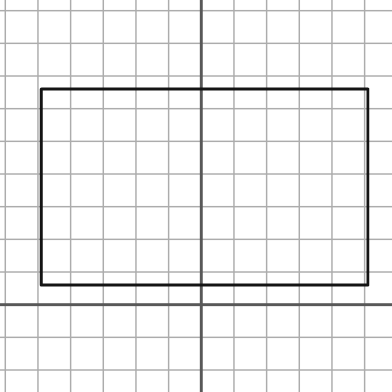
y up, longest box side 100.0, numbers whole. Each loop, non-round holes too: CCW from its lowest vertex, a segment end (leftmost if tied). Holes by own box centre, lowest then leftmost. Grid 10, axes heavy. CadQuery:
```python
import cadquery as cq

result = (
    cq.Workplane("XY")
    .moveTo(-49.0, 6.0)
    .lineTo(51.0, 6.0)
    .lineTo(51.0, 66.0)
    .lineTo(-49.0, 66.0)
    .close()
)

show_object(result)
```